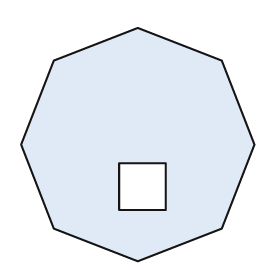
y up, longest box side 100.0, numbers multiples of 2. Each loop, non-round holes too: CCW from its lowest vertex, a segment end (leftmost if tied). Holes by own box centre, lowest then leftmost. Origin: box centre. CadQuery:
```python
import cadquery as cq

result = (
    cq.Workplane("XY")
    .moveTo(0.0, -50.0)
    .lineTo(36.0, -36.0)
    .lineTo(50.0, 0.0)
    .lineTo(36.0, 36.0)
    .lineTo(0.0, 50.0)
    .lineTo(-36.0, 36.0)
    .lineTo(-50.0, 0.0)
    .lineTo(-36.0, -36.0)
    .close()
    .moveTo(-8.0, -28.0)
    .lineTo(12.0, -28.0)
    .lineTo(12.0, -8.0)
    .lineTo(-8.0, -8.0)
    .close()
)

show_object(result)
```